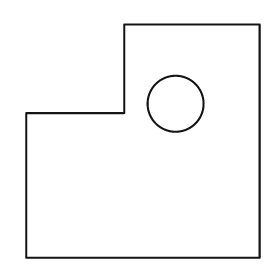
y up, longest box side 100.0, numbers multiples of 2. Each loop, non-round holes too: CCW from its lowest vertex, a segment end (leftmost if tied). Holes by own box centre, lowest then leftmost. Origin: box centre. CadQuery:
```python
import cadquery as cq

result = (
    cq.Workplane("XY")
    .moveTo(-50.0, -50.0)
    .lineTo(50.0, -50.0)
    .lineTo(50.0, 50.0)
    .lineTo(-8.0, 50.0)
    .lineTo(-8.0, 12.0)
    .lineTo(-50.0, 12.0)
    .close()
    .moveTo(14.0, 16.0)
    .circle(12.0)
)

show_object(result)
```